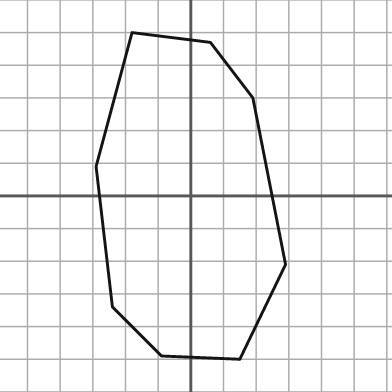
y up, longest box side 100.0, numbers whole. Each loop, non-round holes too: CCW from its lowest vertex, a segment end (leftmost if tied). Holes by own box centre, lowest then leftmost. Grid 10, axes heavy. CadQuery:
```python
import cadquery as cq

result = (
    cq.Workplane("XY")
    .moveTo(15.0, -50.0)
    .lineTo(29.0, -21.0)
    .lineTo(19.0, 30.0)
    .lineTo(6.0, 47.0)
    .lineTo(-18.0, 50.0)
    .lineTo(-29.0, 9.0)
    .lineTo(-24.0, -34.0)
    .lineTo(-9.0, -49.0)
    .close()
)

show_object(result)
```